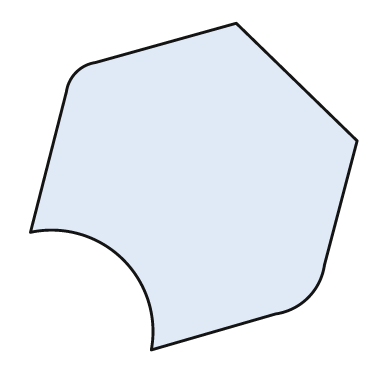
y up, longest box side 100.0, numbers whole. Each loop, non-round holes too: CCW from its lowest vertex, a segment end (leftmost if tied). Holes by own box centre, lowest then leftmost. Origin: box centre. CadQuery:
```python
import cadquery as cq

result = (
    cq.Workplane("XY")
    .moveTo(-13.0, -50.0)
    .lineTo(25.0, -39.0)
    .threePointArc((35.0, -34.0), (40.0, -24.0))
    .lineTo(50.0, 14.0)
    .lineTo(13.0, 50.0)
    .lineTo(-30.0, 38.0)
    .threePointArc((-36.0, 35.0), (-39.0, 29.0))
    .lineTo(-50.0, -14.0)
    .threePointArc((-22.0, -22.0), (-13.0, -50.0))
    .close()
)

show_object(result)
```